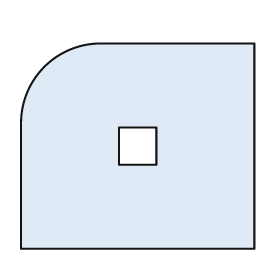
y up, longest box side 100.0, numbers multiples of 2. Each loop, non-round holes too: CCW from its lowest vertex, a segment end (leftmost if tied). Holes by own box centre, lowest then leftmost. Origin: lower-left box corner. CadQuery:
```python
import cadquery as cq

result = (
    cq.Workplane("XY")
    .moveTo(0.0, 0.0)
    .lineTo(100.0, 0.0)
    .lineTo(100.0, 88.0)
    .lineTo(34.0, 88.0)
    .threePointArc((10.0, 78.0), (0.0, 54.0))
    .close()
    .moveTo(42.0, 36.0)
    .lineTo(58.0, 36.0)
    .lineTo(58.0, 52.0)
    .lineTo(42.0, 52.0)
    .close()
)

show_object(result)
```